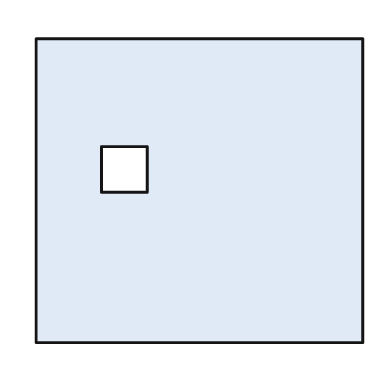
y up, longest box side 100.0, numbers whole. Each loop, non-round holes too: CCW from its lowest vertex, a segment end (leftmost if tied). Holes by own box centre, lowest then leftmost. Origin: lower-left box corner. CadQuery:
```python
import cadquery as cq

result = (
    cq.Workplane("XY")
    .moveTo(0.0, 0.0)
    .lineTo(100.0, 0.0)
    .lineTo(100.0, 93.0)
    .lineTo(0.0, 93.0)
    .close()
    .moveTo(20.0, 46.0)
    .lineTo(34.0, 46.0)
    .lineTo(34.0, 60.0)
    .lineTo(20.0, 60.0)
    .close()
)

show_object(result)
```